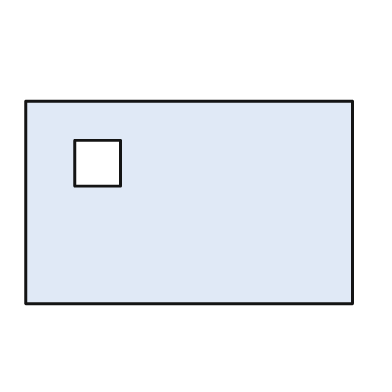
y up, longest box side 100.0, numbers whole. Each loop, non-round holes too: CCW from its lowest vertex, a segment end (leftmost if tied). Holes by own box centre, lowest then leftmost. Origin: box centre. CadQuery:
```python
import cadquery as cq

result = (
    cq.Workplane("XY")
    .moveTo(-50.0, -31.0)
    .lineTo(50.0, -31.0)
    .lineTo(50.0, 31.0)
    .lineTo(-50.0, 31.0)
    .close()
    .moveTo(-35.0, 5.0)
    .lineTo(-21.0, 5.0)
    .lineTo(-21.0, 19.0)
    .lineTo(-35.0, 19.0)
    .close()
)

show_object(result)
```